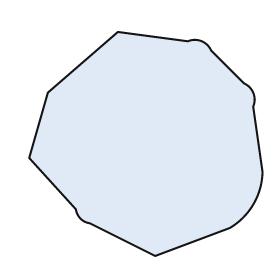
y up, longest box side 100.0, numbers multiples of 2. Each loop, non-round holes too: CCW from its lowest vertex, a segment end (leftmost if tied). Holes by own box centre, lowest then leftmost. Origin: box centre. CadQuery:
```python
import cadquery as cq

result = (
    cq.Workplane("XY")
    .moveTo(4.0, -48.0)
    .lineTo(36.0, -36.0)
    .threePointArc((46.0, -26.0), (50.0, -12.0))
    .lineTo(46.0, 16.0)
    .threePointArc((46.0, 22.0), (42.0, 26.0))
    .lineTo(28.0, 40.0)
    .threePointArc((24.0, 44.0), (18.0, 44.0))
    .lineTo(-12.0, 48.0)
    .lineTo(-42.0, 22.0)
    .lineTo(-50.0, -6.0)
    .lineTo(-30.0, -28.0)
    .threePointArc((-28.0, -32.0), (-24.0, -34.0))
    .close()
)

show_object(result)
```